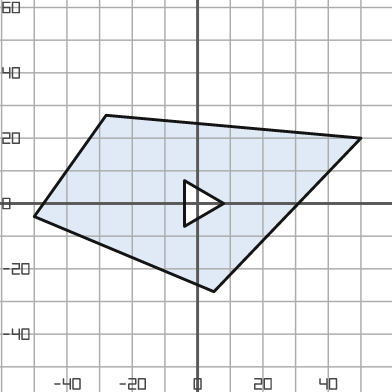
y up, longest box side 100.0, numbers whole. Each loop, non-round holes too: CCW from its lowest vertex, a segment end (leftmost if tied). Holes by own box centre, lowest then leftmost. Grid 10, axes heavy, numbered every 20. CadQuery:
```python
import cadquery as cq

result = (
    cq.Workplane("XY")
    .moveTo(5.0, -27.0)
    .lineTo(50.0, 20.0)
    .lineTo(-28.0, 27.0)
    .lineTo(-50.0, -4.0)
    .close()
    .moveTo(-4.0, -7.0)
    .lineTo(8.0, 0.0)
    .lineTo(-4.0, 7.0)
    .close()
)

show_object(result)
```